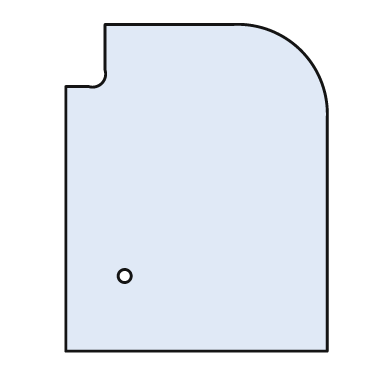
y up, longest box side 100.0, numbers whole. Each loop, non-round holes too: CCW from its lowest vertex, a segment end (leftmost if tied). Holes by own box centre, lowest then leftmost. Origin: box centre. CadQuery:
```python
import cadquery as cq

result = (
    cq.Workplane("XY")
    .moveTo(-40.0, -50.0)
    .lineTo(40.0, -50.0)
    .lineTo(40.0, 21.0)
    .threePointArc((32.0, 42.0), (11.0, 50.0))
    .lineTo(-28.0, 50.0)
    .lineTo(-28.0, 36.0)
    .threePointArc((-29.0, 32.0), (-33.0, 31.0))
    .lineTo(-40.0, 31.0)
    .close()
    .moveTo(-22.0, -27.0)
    .circle(2.0)
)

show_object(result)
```